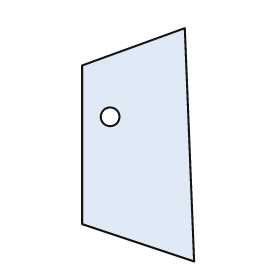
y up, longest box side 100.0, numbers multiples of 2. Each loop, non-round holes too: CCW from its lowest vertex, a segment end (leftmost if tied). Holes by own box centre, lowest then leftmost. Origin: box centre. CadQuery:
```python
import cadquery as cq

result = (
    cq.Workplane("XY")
    .moveTo(24.0, -50.0)
    .lineTo(20.0, 50.0)
    .lineTo(-24.0, 34.0)
    .lineTo(-24.0, -34.0)
    .close()
    .moveTo(-12.0, 12.0)
    .circle(4.0)
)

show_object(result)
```